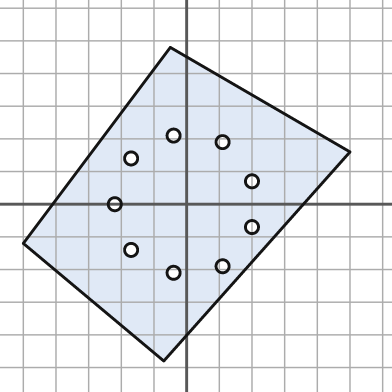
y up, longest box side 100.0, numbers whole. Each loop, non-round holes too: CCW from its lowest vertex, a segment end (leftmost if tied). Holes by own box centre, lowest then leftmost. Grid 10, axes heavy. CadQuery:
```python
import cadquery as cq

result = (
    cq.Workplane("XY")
    .moveTo(-7.0, -48.0)
    .lineTo(50.0, 16.0)
    .lineTo(-5.0, 48.0)
    .lineTo(-50.0, -12.0)
    .close()
    .moveTo(-4.0, -21.0)
    .circle(2.0)
    .moveTo(11.0, -19.0)
    .circle(2.0)
    .moveTo(-17.0, -14.0)
    .circle(2.0)
    .moveTo(20.0, -7.0)
    .circle(2.0)
    .moveTo(-22.0, 0.0)
    .circle(2.0)
    .moveTo(20.0, 7.0)
    .circle(2.0)
    .moveTo(-17.0, 14.0)
    .circle(2.0)
    .moveTo(11.0, 19.0)
    .circle(2.0)
    .moveTo(-4.0, 21.0)
    .circle(2.0)
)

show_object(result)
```